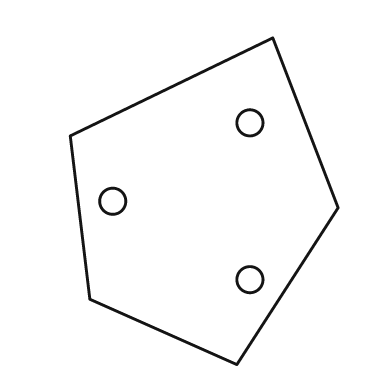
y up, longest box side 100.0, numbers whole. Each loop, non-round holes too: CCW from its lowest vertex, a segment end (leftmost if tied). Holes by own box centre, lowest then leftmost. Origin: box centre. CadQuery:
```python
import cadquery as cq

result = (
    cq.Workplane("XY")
    .moveTo(10.0, -50.0)
    .lineTo(41.0, -2.0)
    .lineTo(21.0, 50.0)
    .lineTo(-41.0, 20.0)
    .lineTo(-35.0, -30.0)
    .close()
    .moveTo(14.0, -24.0)
    .circle(4.0)
    .moveTo(-28.0, 0.0)
    .circle(4.0)
    .moveTo(14.0, 24.0)
    .circle(4.0)
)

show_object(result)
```